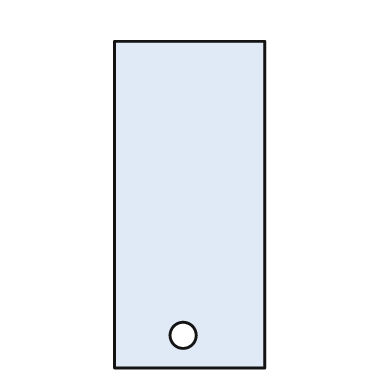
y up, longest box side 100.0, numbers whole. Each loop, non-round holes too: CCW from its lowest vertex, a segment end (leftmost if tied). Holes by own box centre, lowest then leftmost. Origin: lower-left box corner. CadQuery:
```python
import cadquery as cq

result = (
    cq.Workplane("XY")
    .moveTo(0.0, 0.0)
    .lineTo(46.0, 0.0)
    .lineTo(46.0, 100.0)
    .lineTo(0.0, 100.0)
    .close()
    .moveTo(21.0, 10.0)
    .circle(4.0)
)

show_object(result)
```